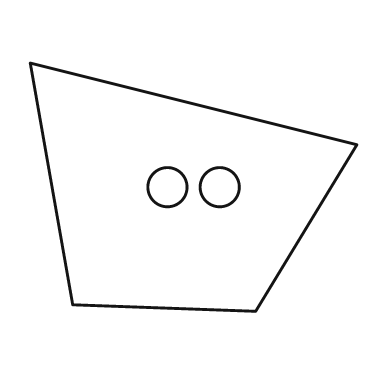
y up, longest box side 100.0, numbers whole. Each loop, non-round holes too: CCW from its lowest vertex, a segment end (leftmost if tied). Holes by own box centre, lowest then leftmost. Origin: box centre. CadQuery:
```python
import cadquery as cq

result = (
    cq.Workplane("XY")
    .moveTo(19.0, -38.0)
    .lineTo(50.0, 13.0)
    .lineTo(-50.0, 38.0)
    .lineTo(-37.0, -36.0)
    .close()
    .moveTo(-8.0, 0.0)
    .circle(6.0)
    .moveTo(8.0, 0.0)
    .circle(6.0)
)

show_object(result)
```